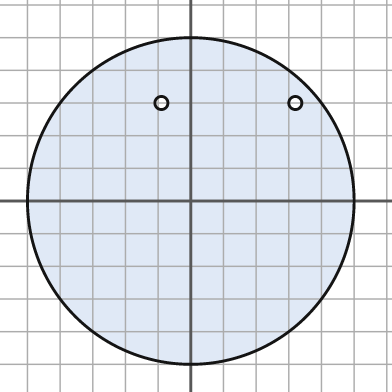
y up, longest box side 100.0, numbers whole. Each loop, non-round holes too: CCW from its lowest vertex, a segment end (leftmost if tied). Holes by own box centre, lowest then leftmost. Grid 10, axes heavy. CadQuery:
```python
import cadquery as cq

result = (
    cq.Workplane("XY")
    .moveTo(0.0, 0.0)
    .circle(50.0)
    .moveTo(-9.0, 30.0)
    .circle(2.0)
    .moveTo(32.0, 30.0)
    .circle(2.0)
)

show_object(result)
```